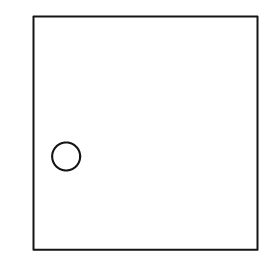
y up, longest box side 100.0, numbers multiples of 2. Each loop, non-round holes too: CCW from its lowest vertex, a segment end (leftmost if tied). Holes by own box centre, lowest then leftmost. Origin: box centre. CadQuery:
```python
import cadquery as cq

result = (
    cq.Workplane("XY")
    .moveTo(-48.0, -50.0)
    .lineTo(48.0, -50.0)
    .lineTo(48.0, 50.0)
    .lineTo(-48.0, 50.0)
    .close()
    .moveTo(-34.0, -10.0)
    .circle(6.0)
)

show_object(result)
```